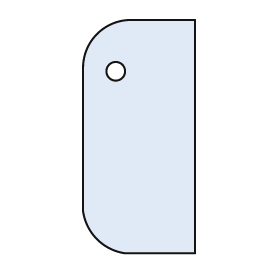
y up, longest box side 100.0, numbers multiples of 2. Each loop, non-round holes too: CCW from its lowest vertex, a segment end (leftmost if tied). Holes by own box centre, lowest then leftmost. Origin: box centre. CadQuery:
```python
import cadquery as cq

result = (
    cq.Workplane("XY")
    .moveTo(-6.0, -50.0)
    .lineTo(24.0, -50.0)
    .lineTo(24.0, 50.0)
    .lineTo(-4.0, 50.0)
    .threePointArc((-18.0, 44.0), (-24.0, 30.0))
    .lineTo(-24.0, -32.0)
    .threePointArc((-18.0, -44.0), (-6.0, -50.0))
    .close()
    .moveTo(-10.0, 28.0)
    .circle(4.0)
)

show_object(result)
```